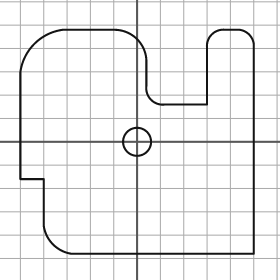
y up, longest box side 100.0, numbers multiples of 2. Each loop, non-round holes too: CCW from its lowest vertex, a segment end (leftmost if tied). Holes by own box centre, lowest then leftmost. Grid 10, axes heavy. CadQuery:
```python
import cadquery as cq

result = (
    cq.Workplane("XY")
    .moveTo(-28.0, -48.0)
    .lineTo(50.0, -48.0)
    .lineTo(50.0, 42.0)
    .threePointArc((48.0, 46.0), (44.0, 48.0))
    .lineTo(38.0, 48.0)
    .threePointArc((32.0, 46.0), (30.0, 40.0))
    .lineTo(30.0, 16.0)
    .lineTo(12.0, 16.0)
    .threePointArc((6.0, 18.0), (4.0, 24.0))
    .lineTo(4.0, 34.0)
    .threePointArc((0.0, 44.0), (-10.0, 48.0))
    .lineTo(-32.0, 48.0)
    .threePointArc((-44.0, 42.0), (-50.0, 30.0))
    .lineTo(-50.0, -16.0)
    .lineTo(-40.0, -16.0)
    .lineTo(-40.0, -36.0)
    .threePointArc((-36.0, -44.0), (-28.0, -48.0))
    .close()
    .moveTo(0.0, 0.0)
    .circle(6.0)
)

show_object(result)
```